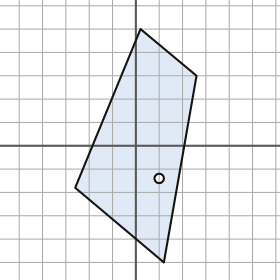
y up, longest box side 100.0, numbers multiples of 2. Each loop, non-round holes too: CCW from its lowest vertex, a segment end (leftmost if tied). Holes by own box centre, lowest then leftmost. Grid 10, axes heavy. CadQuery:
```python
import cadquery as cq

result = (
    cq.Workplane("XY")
    .moveTo(12.0, -50.0)
    .lineTo(26.0, 30.0)
    .lineTo(2.0, 50.0)
    .lineTo(-26.0, -18.0)
    .close()
    .moveTo(10.0, -14.0)
    .circle(2.0)
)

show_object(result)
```